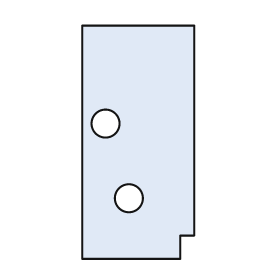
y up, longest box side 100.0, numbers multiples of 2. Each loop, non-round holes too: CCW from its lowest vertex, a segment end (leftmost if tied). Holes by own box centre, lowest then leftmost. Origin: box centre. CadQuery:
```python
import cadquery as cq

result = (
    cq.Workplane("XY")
    .moveTo(-24.0, -50.0)
    .lineTo(18.0, -50.0)
    .lineTo(18.0, -40.0)
    .lineTo(24.0, -40.0)
    .lineTo(24.0, 50.0)
    .lineTo(-24.0, 50.0)
    .close()
    .moveTo(-4.0, -24.0)
    .circle(6.0)
    .moveTo(-14.0, 8.0)
    .circle(6.0)
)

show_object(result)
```